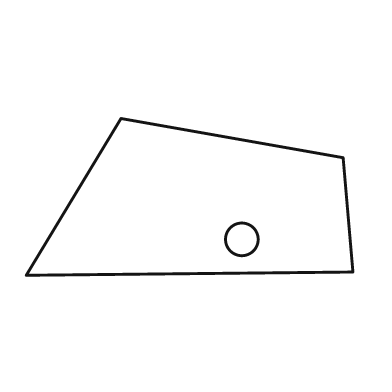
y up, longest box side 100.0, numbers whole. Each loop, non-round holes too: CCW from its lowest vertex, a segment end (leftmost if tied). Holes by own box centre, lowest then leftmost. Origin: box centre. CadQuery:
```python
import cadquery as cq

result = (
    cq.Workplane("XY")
    .moveTo(-50.0, -24.0)
    .lineTo(50.0, -23.0)
    .lineTo(47.0, 12.0)
    .lineTo(-21.0, 24.0)
    .close()
    .moveTo(16.0, -13.0)
    .circle(5.0)
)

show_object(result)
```